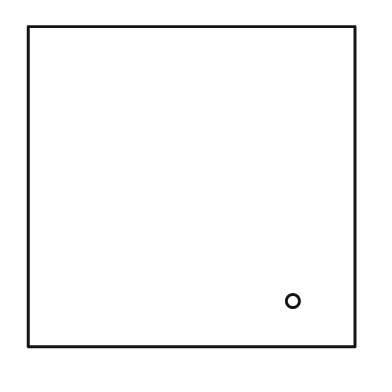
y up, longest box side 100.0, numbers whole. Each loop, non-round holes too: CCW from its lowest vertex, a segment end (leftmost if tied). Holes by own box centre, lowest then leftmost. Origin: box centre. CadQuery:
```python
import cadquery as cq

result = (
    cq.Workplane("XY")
    .moveTo(-50.0, -49.0)
    .lineTo(50.0, -49.0)
    .lineTo(50.0, 49.0)
    .lineTo(-50.0, 49.0)
    .close()
    .moveTo(31.0, -35.0)
    .circle(2.0)
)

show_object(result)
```